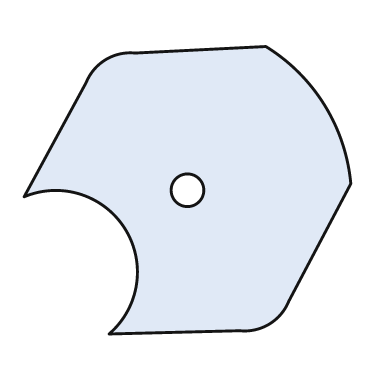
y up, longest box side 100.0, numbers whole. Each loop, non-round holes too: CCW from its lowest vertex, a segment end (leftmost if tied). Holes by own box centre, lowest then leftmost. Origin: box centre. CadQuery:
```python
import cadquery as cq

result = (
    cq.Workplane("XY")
    .moveTo(-24.0, -44.0)
    .lineTo(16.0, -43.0)
    .threePointArc((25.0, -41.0), (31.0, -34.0))
    .lineTo(50.0, 2.0)
    .threePointArc((42.0, 26.0), (24.0, 44.0))
    .lineTo(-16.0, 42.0)
    .threePointArc((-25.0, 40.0), (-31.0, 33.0))
    .lineTo(-50.0, -2.0)
    .threePointArc((-19.0, -12.0), (-24.0, -44.0))
    .close()
    .moveTo(0.0, 0.0)
    .circle(5.0)
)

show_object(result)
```